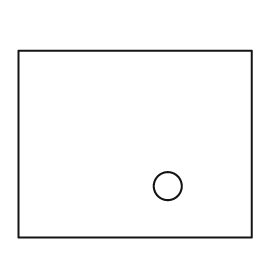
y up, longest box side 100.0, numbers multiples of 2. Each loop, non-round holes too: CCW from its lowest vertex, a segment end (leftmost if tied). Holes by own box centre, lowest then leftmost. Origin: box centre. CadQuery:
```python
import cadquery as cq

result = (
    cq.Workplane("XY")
    .moveTo(-50.0, -40.0)
    .lineTo(50.0, -40.0)
    .lineTo(50.0, 40.0)
    .lineTo(-50.0, 40.0)
    .close()
    .moveTo(14.0, -18.0)
    .circle(6.0)
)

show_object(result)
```